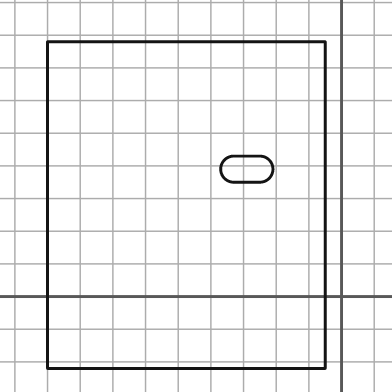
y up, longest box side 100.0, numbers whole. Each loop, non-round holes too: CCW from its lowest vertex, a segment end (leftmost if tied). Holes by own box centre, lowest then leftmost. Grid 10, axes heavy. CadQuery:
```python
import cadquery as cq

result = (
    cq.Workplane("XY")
    .moveTo(-90.0, -22.0)
    .lineTo(-5.0, -22.0)
    .lineTo(-5.0, 78.0)
    .lineTo(-90.0, 78.0)
    .close()
    .moveTo(-33.0, 35.0)
    .lineTo(-25.0, 35.0)
    .threePointArc((-21.0, 39.0), (-25.0, 43.0))
    .lineTo(-33.0, 43.0)
    .threePointArc((-37.0, 39.0), (-33.0, 35.0))
    .close()
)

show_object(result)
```